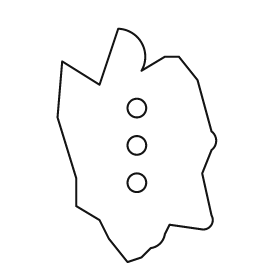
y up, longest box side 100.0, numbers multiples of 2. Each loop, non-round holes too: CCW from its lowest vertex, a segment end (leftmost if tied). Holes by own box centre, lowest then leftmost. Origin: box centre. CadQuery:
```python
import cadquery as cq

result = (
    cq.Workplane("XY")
    .moveTo(-4.0, -50.0)
    .lineTo(2.0, -48.0)
    .lineTo(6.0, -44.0)
    .threePointArc((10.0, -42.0), (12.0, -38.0))
    .lineTo(14.0, -34.0)
    .lineTo(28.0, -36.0)
    .threePointArc((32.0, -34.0), (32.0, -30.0))
    .lineTo(28.0, -12.0)
    .lineTo(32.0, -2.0)
    .threePointArc((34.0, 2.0), (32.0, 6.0))
    .lineTo(26.0, 28.0)
    .lineTo(18.0, 38.0)
    .lineTo(12.0, 38.0)
    .lineTo(2.0, 32.0)
    .threePointArc((2.0, 44.0), (-8.0, 50.0))
    .lineTo(-16.0, 26.0)
    .lineTo(-32.0, 36.0)
    .lineTo(-34.0, 12.0)
    .lineTo(-26.0, -14.0)
    .lineTo(-26.0, -26.0)
    .lineTo(-16.0, -32.0)
    .lineTo(-12.0, -40.0)
    .close()
    .moveTo(0.0, -16.0)
    .circle(4.0)
    .moveTo(0.0, 0.0)
    .circle(4.0)
    .moveTo(0.0, 16.0)
    .circle(4.0)
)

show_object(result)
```